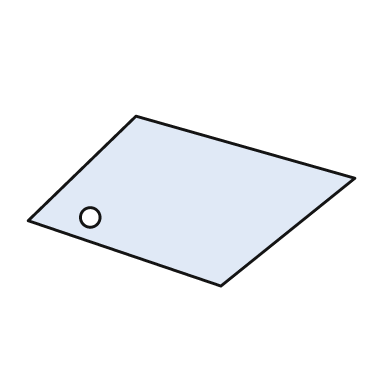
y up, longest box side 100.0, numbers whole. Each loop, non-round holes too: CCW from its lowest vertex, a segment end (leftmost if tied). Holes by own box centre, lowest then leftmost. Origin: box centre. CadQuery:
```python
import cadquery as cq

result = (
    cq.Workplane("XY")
    .moveTo(9.0, -26.0)
    .lineTo(50.0, 7.0)
    .lineTo(-17.0, 26.0)
    .lineTo(-50.0, -6.0)
    .close()
    .moveTo(-31.0, -5.0)
    .circle(3.0)
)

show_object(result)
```